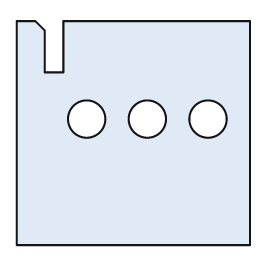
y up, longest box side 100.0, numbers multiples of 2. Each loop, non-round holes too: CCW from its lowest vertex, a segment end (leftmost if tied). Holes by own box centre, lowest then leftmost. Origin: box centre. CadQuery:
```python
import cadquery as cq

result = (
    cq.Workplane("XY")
    .moveTo(-50.0, -48.0)
    .lineTo(50.0, -48.0)
    .lineTo(50.0, 48.0)
    .lineTo(-30.0, 48.0)
    .lineTo(-30.0, 26.0)
    .lineTo(-38.0, 26.0)
    .lineTo(-38.0, 44.0)
    .lineTo(-42.0, 48.0)
    .lineTo(-50.0, 48.0)
    .close()
    .moveTo(-20.0, 6.0)
    .circle(8.0)
    .moveTo(6.0, 6.0)
    .circle(8.0)
    .moveTo(32.0, 6.0)
    .circle(8.0)
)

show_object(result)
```